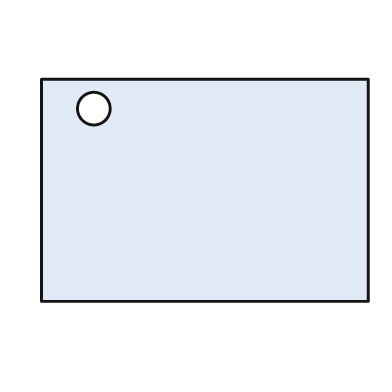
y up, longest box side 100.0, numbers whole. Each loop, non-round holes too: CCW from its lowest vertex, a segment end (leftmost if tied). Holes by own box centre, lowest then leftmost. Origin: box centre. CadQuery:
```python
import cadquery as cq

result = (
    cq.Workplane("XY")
    .moveTo(-50.0, -34.0)
    .lineTo(50.0, -34.0)
    .lineTo(50.0, 34.0)
    .lineTo(-50.0, 34.0)
    .close()
    .moveTo(-34.0, 25.0)
    .circle(5.0)
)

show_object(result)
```